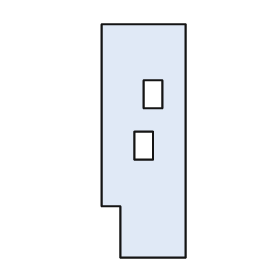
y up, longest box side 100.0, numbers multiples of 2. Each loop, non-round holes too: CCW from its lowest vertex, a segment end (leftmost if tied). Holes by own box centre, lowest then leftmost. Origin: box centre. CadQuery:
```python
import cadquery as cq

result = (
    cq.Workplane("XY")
    .moveTo(-10.0, -50.0)
    .lineTo(18.0, -50.0)
    .lineTo(18.0, 50.0)
    .lineTo(-18.0, 50.0)
    .lineTo(-18.0, -28.0)
    .lineTo(-10.0, -28.0)
    .close()
    .moveTo(-4.0, -8.0)
    .lineTo(4.0, -8.0)
    .lineTo(4.0, 4.0)
    .lineTo(-4.0, 4.0)
    .close()
    .moveTo(0.0, 14.0)
    .lineTo(8.0, 14.0)
    .lineTo(8.0, 26.0)
    .lineTo(0.0, 26.0)
    .close()
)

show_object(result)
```